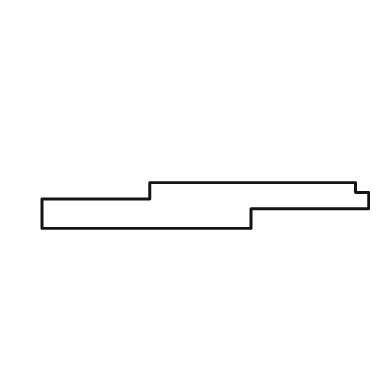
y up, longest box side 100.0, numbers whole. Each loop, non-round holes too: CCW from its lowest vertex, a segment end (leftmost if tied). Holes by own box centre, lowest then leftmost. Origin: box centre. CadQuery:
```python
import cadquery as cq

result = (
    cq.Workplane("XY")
    .moveTo(-50.0, -7.0)
    .lineTo(14.0, -7.0)
    .lineTo(14.0, -1.0)
    .lineTo(50.0, -1.0)
    .lineTo(50.0, 4.0)
    .lineTo(46.0, 4.0)
    .lineTo(46.0, 7.0)
    .lineTo(-17.0, 7.0)
    .lineTo(-17.0, 2.0)
    .lineTo(-50.0, 2.0)
    .close()
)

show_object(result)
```